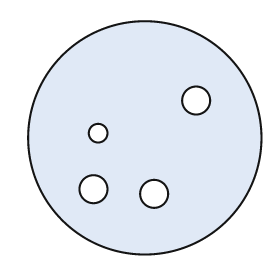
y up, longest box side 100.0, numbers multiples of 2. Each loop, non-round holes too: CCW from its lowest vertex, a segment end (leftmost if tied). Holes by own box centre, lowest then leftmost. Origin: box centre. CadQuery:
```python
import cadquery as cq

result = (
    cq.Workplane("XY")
    .moveTo(0.0, 0.0)
    .circle(50.0)
    .moveTo(4.0, -24.0)
    .circle(6.0)
    .moveTo(-22.0, -22.0)
    .circle(6.0)
    .moveTo(-20.0, 2.0)
    .circle(4.0)
    .moveTo(22.0, 16.0)
    .circle(6.0)
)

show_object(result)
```